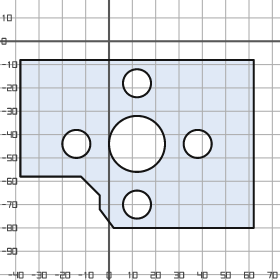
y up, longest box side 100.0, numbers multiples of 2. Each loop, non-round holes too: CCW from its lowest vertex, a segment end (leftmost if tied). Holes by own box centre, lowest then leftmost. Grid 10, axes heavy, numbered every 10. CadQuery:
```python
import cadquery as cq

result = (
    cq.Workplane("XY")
    .moveTo(2.0, -80.0)
    .lineTo(62.0, -80.0)
    .lineTo(62.0, -8.0)
    .lineTo(-38.0, -8.0)
    .lineTo(-38.0, -58.0)
    .lineTo(-12.0, -58.0)
    .lineTo(-4.0, -66.0)
    .lineTo(-4.0, -72.0)
    .close()
    .moveTo(12.0, -70.0)
    .circle(6.0)
    .moveTo(-14.0, -44.0)
    .circle(6.0)
    .moveTo(12.0, -44.0)
    .circle(12.0)
    .moveTo(38.0, -44.0)
    .circle(6.0)
    .moveTo(12.0, -18.0)
    .circle(6.0)
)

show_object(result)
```